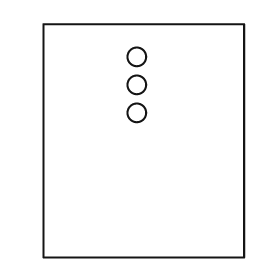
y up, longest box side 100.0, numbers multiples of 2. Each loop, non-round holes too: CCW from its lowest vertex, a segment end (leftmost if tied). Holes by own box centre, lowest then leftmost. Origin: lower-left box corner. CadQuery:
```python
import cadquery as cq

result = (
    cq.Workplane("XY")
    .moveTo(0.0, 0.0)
    .lineTo(86.0, 0.0)
    .lineTo(86.0, 100.0)
    .lineTo(0.0, 100.0)
    .close()
    .moveTo(40.0, 62.0)
    .circle(4.0)
    .moveTo(40.0, 74.0)
    .circle(4.0)
    .moveTo(40.0, 86.0)
    .circle(4.0)
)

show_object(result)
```